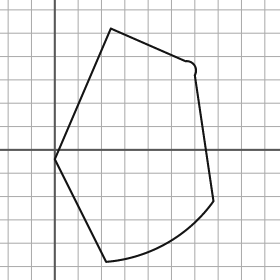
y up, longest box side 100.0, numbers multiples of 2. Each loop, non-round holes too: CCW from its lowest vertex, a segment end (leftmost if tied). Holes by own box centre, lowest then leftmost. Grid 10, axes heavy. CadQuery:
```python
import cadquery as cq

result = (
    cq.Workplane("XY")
    .moveTo(22.0, -48.0)
    .threePointArc((48.0, -40.0), (68.0, -22.0))
    .lineTo(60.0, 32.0)
    .threePointArc((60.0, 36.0), (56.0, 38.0))
    .lineTo(24.0, 52.0)
    .lineTo(0.0, -4.0)
    .close()
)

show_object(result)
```